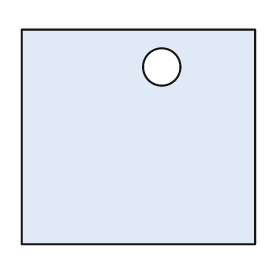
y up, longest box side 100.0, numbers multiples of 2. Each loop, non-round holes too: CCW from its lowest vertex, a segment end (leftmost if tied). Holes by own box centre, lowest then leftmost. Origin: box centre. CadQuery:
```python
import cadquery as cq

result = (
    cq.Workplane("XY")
    .moveTo(-50.0, -46.0)
    .lineTo(50.0, -46.0)
    .lineTo(50.0, 46.0)
    .lineTo(-50.0, 46.0)
    .close()
    .moveTo(10.0, 30.0)
    .circle(8.0)
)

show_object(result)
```